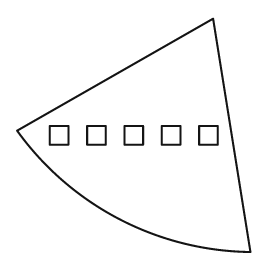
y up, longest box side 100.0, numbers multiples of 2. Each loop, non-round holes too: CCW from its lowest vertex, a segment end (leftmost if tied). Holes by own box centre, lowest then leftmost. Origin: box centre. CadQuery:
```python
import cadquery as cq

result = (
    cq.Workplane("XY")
    .moveTo(50.0, -50.0)
    .lineTo(34.0, 50.0)
    .lineTo(-50.0, 2.0)
    .threePointArc((-6.0, -36.0), (50.0, -50.0))
    .close()
    .moveTo(-36.0, -4.0)
    .lineTo(-28.0, -4.0)
    .lineTo(-28.0, 4.0)
    .lineTo(-36.0, 4.0)
    .close()
    .moveTo(-20.0, -4.0)
    .lineTo(-12.0, -4.0)
    .lineTo(-12.0, 4.0)
    .lineTo(-20.0, 4.0)
    .close()
    .moveTo(-4.0, -4.0)
    .lineTo(4.0, -4.0)
    .lineTo(4.0, 4.0)
    .lineTo(-4.0, 4.0)
    .close()
    .moveTo(12.0, -4.0)
    .lineTo(20.0, -4.0)
    .lineTo(20.0, 4.0)
    .lineTo(12.0, 4.0)
    .close()
    .moveTo(28.0, -4.0)
    .lineTo(36.0, -4.0)
    .lineTo(36.0, 4.0)
    .lineTo(28.0, 4.0)
    .close()
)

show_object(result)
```